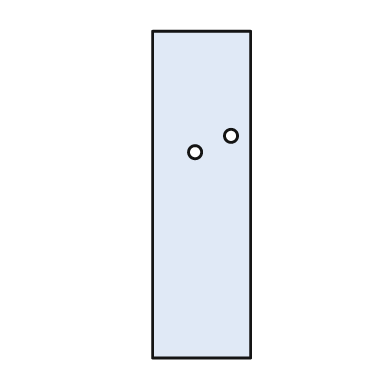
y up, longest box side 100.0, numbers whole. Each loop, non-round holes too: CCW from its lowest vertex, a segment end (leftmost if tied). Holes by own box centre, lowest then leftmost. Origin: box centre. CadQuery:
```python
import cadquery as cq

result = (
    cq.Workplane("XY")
    .moveTo(-15.0, -50.0)
    .lineTo(15.0, -50.0)
    .lineTo(15.0, 50.0)
    .lineTo(-15.0, 50.0)
    .close()
    .moveTo(-2.0, 13.0)
    .circle(2.0)
    .moveTo(9.0, 18.0)
    .circle(2.0)
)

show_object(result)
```